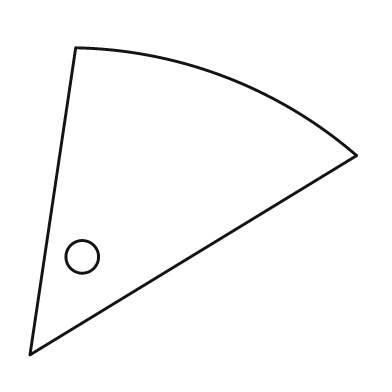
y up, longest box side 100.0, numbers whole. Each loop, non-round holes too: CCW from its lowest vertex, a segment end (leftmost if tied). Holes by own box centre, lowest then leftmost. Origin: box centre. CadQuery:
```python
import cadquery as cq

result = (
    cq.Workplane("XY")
    .moveTo(-50.0, -47.0)
    .lineTo(50.0, 14.0)
    .threePointArc((10.0, 38.0), (-36.0, 47.0))
    .close()
    .moveTo(-34.0, -17.0)
    .circle(5.0)
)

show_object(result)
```